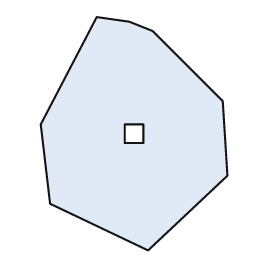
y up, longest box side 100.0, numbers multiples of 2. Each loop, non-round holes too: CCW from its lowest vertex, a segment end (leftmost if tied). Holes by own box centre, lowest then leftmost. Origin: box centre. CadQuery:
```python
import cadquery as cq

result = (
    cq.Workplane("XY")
    .moveTo(6.0, -50.0)
    .lineTo(40.0, -18.0)
    .lineTo(38.0, 14.0)
    .lineTo(8.0, 44.0)
    .lineTo(-2.0, 48.0)
    .lineTo(-16.0, 50.0)
    .lineTo(-40.0, 4.0)
    .lineTo(-36.0, -30.0)
    .close()
    .moveTo(-4.0, -4.0)
    .lineTo(4.0, -4.0)
    .lineTo(4.0, 4.0)
    .lineTo(-4.0, 4.0)
    .close()
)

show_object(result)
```